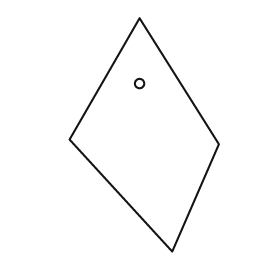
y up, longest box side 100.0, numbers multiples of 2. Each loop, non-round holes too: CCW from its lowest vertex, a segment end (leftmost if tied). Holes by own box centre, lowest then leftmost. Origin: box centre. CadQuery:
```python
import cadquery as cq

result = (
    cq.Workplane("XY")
    .moveTo(12.0, -50.0)
    .lineTo(32.0, -4.0)
    .lineTo(-2.0, 50.0)
    .lineTo(-32.0, -2.0)
    .close()
    .moveTo(-2.0, 22.0)
    .circle(2.0)
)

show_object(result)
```